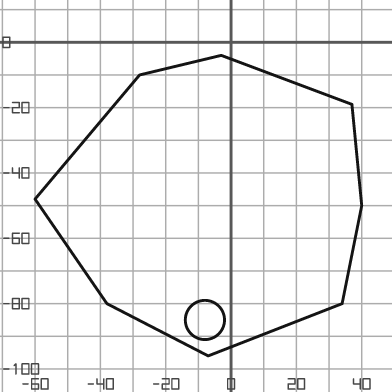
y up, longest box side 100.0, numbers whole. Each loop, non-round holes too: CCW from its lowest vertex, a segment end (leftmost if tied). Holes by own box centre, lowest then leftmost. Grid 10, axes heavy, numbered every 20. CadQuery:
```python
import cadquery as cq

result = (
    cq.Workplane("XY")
    .moveTo(-7.0, -96.0)
    .lineTo(34.0, -80.0)
    .lineTo(40.0, -50.0)
    .lineTo(37.0, -19.0)
    .lineTo(-3.0, -4.0)
    .lineTo(-28.0, -10.0)
    .lineTo(-60.0, -48.0)
    .lineTo(-38.0, -80.0)
    .close()
    .moveTo(-8.0, -85.0)
    .circle(6.0)
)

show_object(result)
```